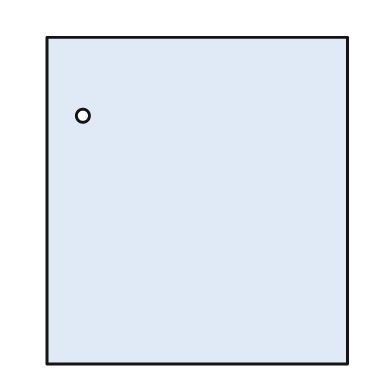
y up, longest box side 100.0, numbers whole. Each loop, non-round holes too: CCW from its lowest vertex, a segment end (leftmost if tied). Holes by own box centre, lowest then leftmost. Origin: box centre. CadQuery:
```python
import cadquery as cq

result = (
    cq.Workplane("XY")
    .moveTo(-46.0, -50.0)
    .lineTo(46.0, -50.0)
    .lineTo(46.0, 50.0)
    .lineTo(-46.0, 50.0)
    .close()
    .moveTo(-35.0, 26.0)
    .circle(2.0)
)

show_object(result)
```